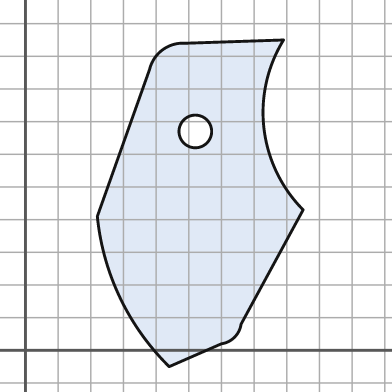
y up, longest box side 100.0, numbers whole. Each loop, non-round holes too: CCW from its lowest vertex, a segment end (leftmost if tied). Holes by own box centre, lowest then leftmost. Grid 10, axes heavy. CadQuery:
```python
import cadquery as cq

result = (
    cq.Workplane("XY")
    .moveTo(44.0, -5.0)
    .lineTo(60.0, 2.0)
    .threePointArc((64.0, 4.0), (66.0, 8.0))
    .lineTo(85.0, 43.0)
    .threePointArc((73.0, 68.0), (79.0, 95.0))
    .lineTo(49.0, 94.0)
    .threePointArc((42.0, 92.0), (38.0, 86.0))
    .lineTo(22.0, 41.0)
    .threePointArc((29.0, 16.0), (44.0, -5.0))
    .close()
    .moveTo(52.0, 67.0)
    .circle(5.0)
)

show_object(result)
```